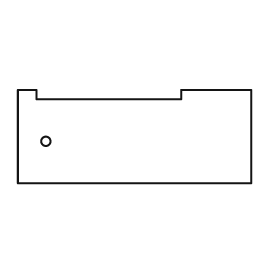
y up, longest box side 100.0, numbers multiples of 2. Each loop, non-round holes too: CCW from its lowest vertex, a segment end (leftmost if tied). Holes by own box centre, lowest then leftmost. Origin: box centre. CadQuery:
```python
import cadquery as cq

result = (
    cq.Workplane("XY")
    .moveTo(-50.0, -20.0)
    .lineTo(50.0, -20.0)
    .lineTo(50.0, 20.0)
    .lineTo(20.0, 20.0)
    .lineTo(20.0, 16.0)
    .lineTo(-42.0, 16.0)
    .lineTo(-42.0, 20.0)
    .lineTo(-50.0, 20.0)
    .close()
    .moveTo(-38.0, -2.0)
    .circle(2.0)
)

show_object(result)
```